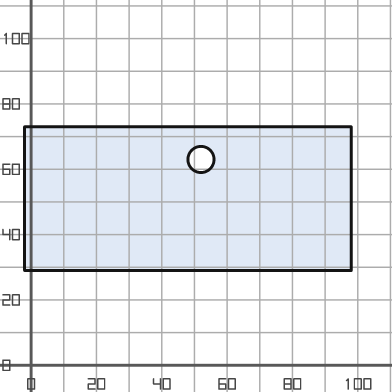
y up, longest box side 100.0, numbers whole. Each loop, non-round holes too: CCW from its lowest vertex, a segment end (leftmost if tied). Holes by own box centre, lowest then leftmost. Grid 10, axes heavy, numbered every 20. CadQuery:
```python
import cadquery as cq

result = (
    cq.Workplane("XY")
    .moveTo(-2.0, 29.0)
    .lineTo(98.0, 29.0)
    .lineTo(98.0, 73.0)
    .lineTo(-2.0, 73.0)
    .close()
    .moveTo(52.0, 63.0)
    .circle(4.0)
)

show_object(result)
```